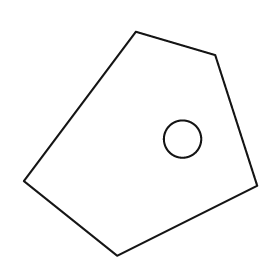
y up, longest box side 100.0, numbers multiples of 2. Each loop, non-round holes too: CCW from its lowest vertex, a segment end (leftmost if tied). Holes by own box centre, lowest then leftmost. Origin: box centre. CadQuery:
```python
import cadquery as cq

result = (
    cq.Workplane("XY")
    .moveTo(-10.0, -48.0)
    .lineTo(50.0, -18.0)
    .lineTo(32.0, 38.0)
    .lineTo(-2.0, 48.0)
    .lineTo(-50.0, -16.0)
    .close()
    .moveTo(18.0, 2.0)
    .circle(8.0)
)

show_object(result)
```